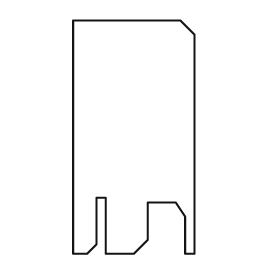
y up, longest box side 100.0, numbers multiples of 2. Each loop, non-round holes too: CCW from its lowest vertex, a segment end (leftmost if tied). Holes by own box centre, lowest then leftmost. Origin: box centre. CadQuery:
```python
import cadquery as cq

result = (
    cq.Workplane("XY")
    .moveTo(-26.0, -50.0)
    .lineTo(-20.0, -50.0)
    .lineTo(-16.0, -46.0)
    .lineTo(-16.0, -26.0)
    .lineTo(-12.0, -26.0)
    .lineTo(-12.0, -50.0)
    .lineTo(0.0, -50.0)
    .lineTo(6.0, -44.0)
    .lineTo(6.0, -28.0)
    .lineTo(18.0, -28.0)
    .lineTo(22.0, -34.0)
    .lineTo(22.0, -50.0)
    .lineTo(26.0, -50.0)
    .lineTo(26.0, 44.0)
    .lineTo(20.0, 50.0)
    .lineTo(-26.0, 50.0)
    .close()
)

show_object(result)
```